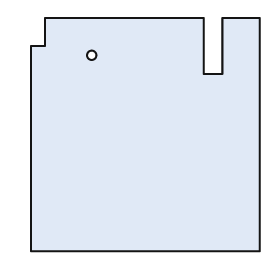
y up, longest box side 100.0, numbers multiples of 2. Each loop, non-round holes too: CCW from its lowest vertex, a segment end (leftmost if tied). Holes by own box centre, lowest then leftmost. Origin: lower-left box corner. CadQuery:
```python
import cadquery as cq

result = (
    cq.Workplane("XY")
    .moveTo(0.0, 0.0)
    .lineTo(98.0, 0.0)
    .lineTo(98.0, 100.0)
    .lineTo(82.0, 100.0)
    .lineTo(82.0, 76.0)
    .lineTo(74.0, 76.0)
    .lineTo(74.0, 100.0)
    .lineTo(6.0, 100.0)
    .lineTo(6.0, 88.0)
    .lineTo(0.0, 88.0)
    .close()
    .moveTo(26.0, 84.0)
    .circle(2.0)
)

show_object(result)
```